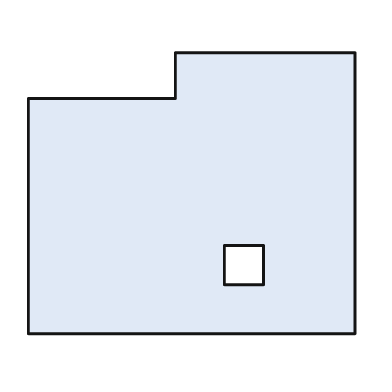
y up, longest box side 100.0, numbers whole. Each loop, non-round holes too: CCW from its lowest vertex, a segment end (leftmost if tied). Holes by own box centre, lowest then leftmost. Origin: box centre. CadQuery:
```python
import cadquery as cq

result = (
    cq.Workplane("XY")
    .moveTo(-50.0, -43.0)
    .lineTo(50.0, -43.0)
    .lineTo(50.0, 43.0)
    .lineTo(-5.0, 43.0)
    .lineTo(-5.0, 29.0)
    .lineTo(-50.0, 29.0)
    .close()
    .moveTo(10.0, -28.0)
    .lineTo(22.0, -28.0)
    .lineTo(22.0, -16.0)
    .lineTo(10.0, -16.0)
    .close()
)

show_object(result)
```